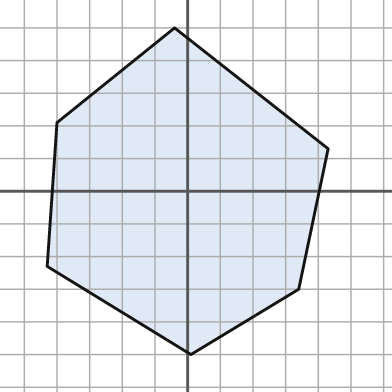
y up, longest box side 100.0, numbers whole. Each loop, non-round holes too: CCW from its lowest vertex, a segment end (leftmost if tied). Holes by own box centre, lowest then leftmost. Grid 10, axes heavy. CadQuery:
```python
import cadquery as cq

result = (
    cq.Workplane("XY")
    .moveTo(1.0, -50.0)
    .lineTo(34.0, -30.0)
    .lineTo(43.0, 13.0)
    .lineTo(-4.0, 50.0)
    .lineTo(-40.0, 21.0)
    .lineTo(-43.0, -23.0)
    .close()
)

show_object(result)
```